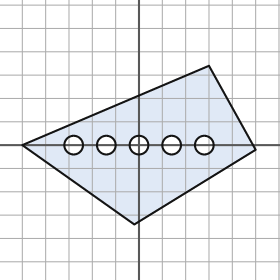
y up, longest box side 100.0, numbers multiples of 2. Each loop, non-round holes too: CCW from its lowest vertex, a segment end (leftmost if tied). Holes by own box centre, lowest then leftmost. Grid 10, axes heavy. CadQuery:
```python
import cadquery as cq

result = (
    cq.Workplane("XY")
    .moveTo(-2.0, -34.0)
    .lineTo(50.0, -2.0)
    .lineTo(30.0, 34.0)
    .lineTo(-50.0, 0.0)
    .close()
    .moveTo(-28.0, 0.0)
    .circle(4.0)
    .moveTo(-14.0, 0.0)
    .circle(4.0)
    .moveTo(0.0, 0.0)
    .circle(4.0)
    .moveTo(14.0, 0.0)
    .circle(4.0)
    .moveTo(28.0, 0.0)
    .circle(4.0)
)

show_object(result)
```